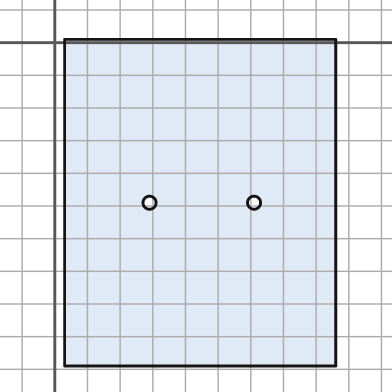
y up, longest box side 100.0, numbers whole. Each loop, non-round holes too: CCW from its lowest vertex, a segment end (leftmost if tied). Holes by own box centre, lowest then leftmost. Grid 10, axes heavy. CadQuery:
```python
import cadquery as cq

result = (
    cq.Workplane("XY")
    .moveTo(3.0, -99.0)
    .lineTo(86.0, -99.0)
    .lineTo(86.0, 1.0)
    .lineTo(3.0, 1.0)
    .close()
    .moveTo(29.0, -49.0)
    .circle(2.0)
    .moveTo(61.0, -49.0)
    .circle(2.0)
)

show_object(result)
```